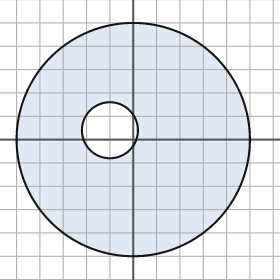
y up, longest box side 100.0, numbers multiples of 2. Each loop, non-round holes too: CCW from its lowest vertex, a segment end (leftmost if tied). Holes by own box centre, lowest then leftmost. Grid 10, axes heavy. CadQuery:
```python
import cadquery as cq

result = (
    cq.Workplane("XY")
    .moveTo(0.0, 0.0)
    .circle(50.0)
    .moveTo(-10.0, 4.0)
    .circle(12.0)
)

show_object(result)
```